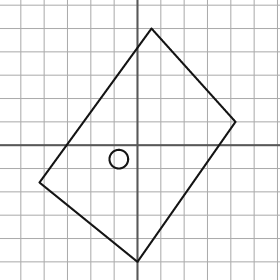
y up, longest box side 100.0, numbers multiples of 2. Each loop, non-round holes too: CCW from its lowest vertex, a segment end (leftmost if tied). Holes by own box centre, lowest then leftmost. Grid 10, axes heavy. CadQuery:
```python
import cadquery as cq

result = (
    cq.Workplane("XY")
    .moveTo(0.0, -50.0)
    .lineTo(42.0, 10.0)
    .lineTo(6.0, 50.0)
    .lineTo(-42.0, -16.0)
    .close()
    .moveTo(-8.0, -6.0)
    .circle(4.0)
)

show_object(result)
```